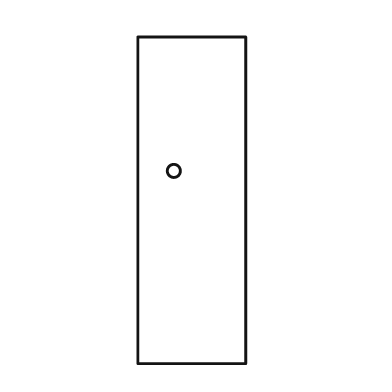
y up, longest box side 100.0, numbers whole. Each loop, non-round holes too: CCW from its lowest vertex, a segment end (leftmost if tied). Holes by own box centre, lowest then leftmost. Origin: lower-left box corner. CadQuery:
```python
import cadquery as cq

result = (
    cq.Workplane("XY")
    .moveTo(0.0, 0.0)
    .lineTo(33.0, 0.0)
    .lineTo(33.0, 100.0)
    .lineTo(0.0, 100.0)
    .close()
    .moveTo(11.0, 59.0)
    .circle(2.0)
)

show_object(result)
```